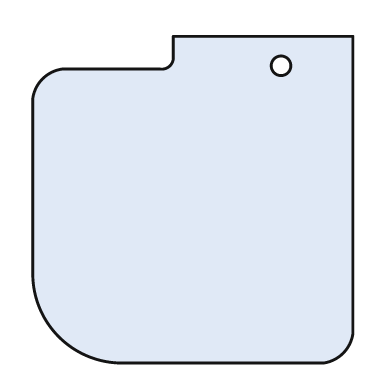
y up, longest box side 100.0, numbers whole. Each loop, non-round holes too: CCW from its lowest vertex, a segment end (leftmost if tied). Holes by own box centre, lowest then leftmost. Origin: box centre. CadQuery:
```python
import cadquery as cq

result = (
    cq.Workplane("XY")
    .moveTo(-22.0, -50.0)
    .lineTo(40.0, -50.0)
    .threePointArc((46.0, -47.0), (49.0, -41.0))
    .lineTo(49.0, 50.0)
    .lineTo(-6.0, 50.0)
    .lineTo(-6.0, 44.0)
    .threePointArc((-7.0, 41.0), (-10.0, 40.0))
    .lineTo(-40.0, 40.0)
    .threePointArc((-46.0, 37.0), (-49.0, 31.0))
    .lineTo(-49.0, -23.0)
    .threePointArc((-41.0, -42.0), (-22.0, -50.0))
    .close()
    .moveTo(27.0, 41.0)
    .circle(3.0)
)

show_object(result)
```